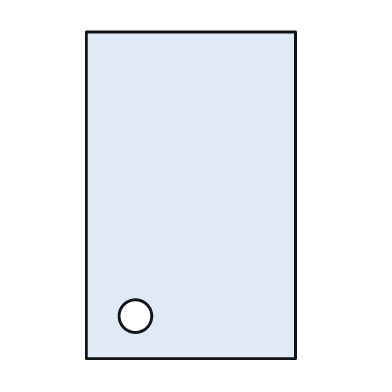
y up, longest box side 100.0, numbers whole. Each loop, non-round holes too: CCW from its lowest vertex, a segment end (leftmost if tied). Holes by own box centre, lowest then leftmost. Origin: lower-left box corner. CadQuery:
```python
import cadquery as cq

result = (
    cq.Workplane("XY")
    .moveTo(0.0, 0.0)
    .lineTo(64.0, 0.0)
    .lineTo(64.0, 100.0)
    .lineTo(0.0, 100.0)
    .close()
    .moveTo(15.0, 13.0)
    .circle(5.0)
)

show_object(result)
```